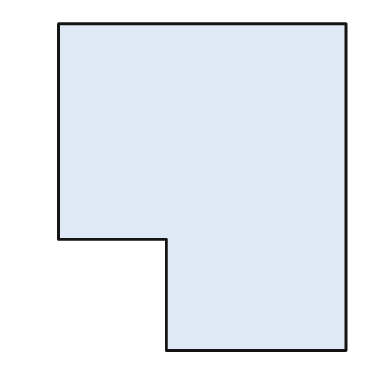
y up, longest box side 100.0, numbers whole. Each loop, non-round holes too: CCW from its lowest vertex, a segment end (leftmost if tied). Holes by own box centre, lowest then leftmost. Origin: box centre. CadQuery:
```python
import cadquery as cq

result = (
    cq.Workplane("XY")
    .moveTo(-11.0, -50.0)
    .lineTo(44.0, -50.0)
    .lineTo(44.0, 50.0)
    .lineTo(-44.0, 50.0)
    .lineTo(-44.0, -16.0)
    .lineTo(-11.0, -16.0)
    .close()
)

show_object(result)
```